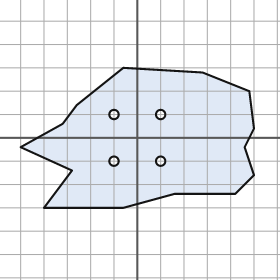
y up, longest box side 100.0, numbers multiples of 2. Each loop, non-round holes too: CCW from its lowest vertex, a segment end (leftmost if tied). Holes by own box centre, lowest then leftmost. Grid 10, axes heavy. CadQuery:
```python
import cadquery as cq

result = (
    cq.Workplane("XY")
    .moveTo(-40.0, -30.0)
    .lineTo(-6.0, -30.0)
    .lineTo(16.0, -24.0)
    .lineTo(42.0, -24.0)
    .lineTo(50.0, -16.0)
    .lineTo(46.0, -4.0)
    .lineTo(50.0, 4.0)
    .lineTo(48.0, 20.0)
    .lineTo(28.0, 28.0)
    .lineTo(-6.0, 30.0)
    .lineTo(-26.0, 14.0)
    .lineTo(-32.0, 6.0)
    .lineTo(-50.0, -4.0)
    .lineTo(-28.0, -14.0)
    .close()
    .moveTo(-10.0, -10.0)
    .circle(2.0)
    .moveTo(10.0, -10.0)
    .circle(2.0)
    .moveTo(-10.0, 10.0)
    .circle(2.0)
    .moveTo(10.0, 10.0)
    .circle(2.0)
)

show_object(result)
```